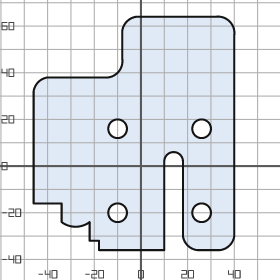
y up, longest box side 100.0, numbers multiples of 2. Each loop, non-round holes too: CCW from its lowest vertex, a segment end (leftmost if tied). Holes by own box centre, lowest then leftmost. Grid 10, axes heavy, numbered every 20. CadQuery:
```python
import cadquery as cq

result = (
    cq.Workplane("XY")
    .moveTo(-18.0, -36.0)
    .lineTo(10.0, -36.0)
    .lineTo(10.0, 2.0)
    .threePointArc((14.0, 6.0), (18.0, 2.0))
    .lineTo(18.0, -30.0)
    .threePointArc((20.0, -34.0), (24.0, -36.0))
    .lineTo(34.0, -36.0)
    .threePointArc((38.0, -34.0), (40.0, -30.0))
    .lineTo(40.0, 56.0)
    .threePointArc((38.0, 62.0), (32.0, 64.0))
    .lineTo(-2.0, 64.0)
    .threePointArc((-6.0, 62.0), (-8.0, 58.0))
    .lineTo(-8.0, 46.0)
    .threePointArc((-10.0, 40.0), (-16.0, 38.0))
    .lineTo(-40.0, 38.0)
    .threePointArc((-44.0, 36.0), (-46.0, 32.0))
    .lineTo(-46.0, -16.0)
    .lineTo(-34.0, -16.0)
    .lineTo(-34.0, -24.0)
    .threePointArc((-28.0, -26.0), (-22.0, -24.0))
    .lineTo(-22.0, -32.0)
    .lineTo(-18.0, -32.0)
    .close()
    .moveTo(-10.0, -20.0)
    .circle(4.0)
    .moveTo(26.0, -20.0)
    .circle(4.0)
    .moveTo(-10.0, 16.0)
    .circle(4.0)
    .moveTo(26.0, 16.0)
    .circle(4.0)
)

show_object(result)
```